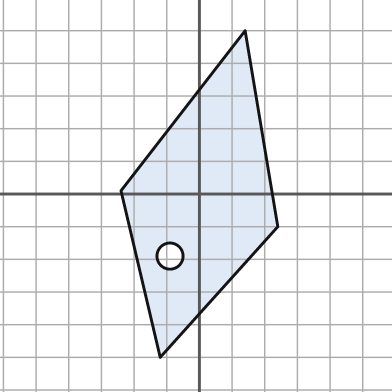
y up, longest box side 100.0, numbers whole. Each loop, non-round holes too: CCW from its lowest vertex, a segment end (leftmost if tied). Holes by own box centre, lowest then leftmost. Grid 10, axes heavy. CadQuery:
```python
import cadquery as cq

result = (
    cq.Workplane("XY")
    .moveTo(-12.0, -50.0)
    .lineTo(24.0, -10.0)
    .lineTo(14.0, 50.0)
    .lineTo(-24.0, 1.0)
    .close()
    .moveTo(-9.0, -19.0)
    .circle(4.0)
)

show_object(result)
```